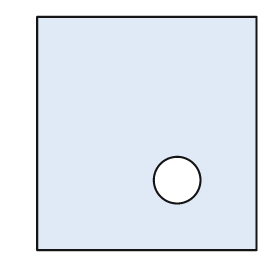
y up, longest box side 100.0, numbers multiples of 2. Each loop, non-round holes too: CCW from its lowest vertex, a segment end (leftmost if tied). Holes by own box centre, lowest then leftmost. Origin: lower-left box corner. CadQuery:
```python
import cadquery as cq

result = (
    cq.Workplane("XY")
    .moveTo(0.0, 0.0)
    .lineTo(94.0, 0.0)
    .lineTo(94.0, 100.0)
    .lineTo(0.0, 100.0)
    .close()
    .moveTo(60.0, 30.0)
    .circle(10.0)
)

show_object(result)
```